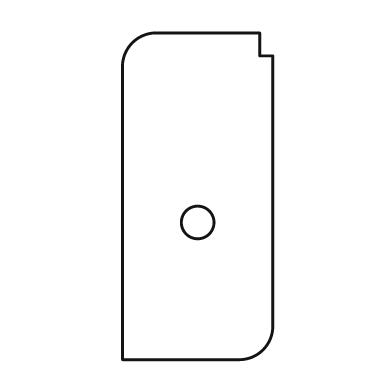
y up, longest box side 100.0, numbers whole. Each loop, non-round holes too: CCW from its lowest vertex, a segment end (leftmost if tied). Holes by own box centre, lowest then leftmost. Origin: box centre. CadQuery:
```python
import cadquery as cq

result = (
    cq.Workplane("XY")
    .moveTo(-23.0, -50.0)
    .lineTo(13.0, -50.0)
    .threePointArc((20.0, -47.0), (23.0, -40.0))
    .lineTo(23.0, 43.0)
    .lineTo(19.0, 43.0)
    .lineTo(19.0, 50.0)
    .lineTo(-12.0, 50.0)
    .threePointArc((-20.0, 47.0), (-23.0, 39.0))
    .close()
    .moveTo(0.0, -8.0)
    .circle(5.0)
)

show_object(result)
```